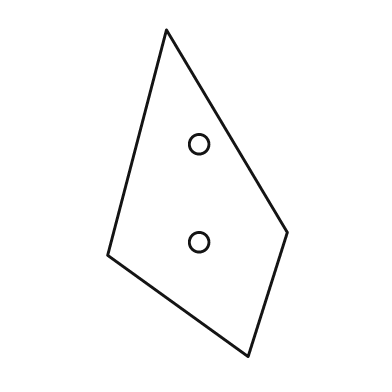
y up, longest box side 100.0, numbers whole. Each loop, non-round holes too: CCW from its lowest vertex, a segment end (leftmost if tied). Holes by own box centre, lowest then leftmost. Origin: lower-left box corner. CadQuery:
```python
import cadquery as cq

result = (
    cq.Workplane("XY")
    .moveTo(43.0, 0.0)
    .lineTo(55.0, 38.0)
    .lineTo(18.0, 100.0)
    .lineTo(0.0, 31.0)
    .close()
    .moveTo(28.0, 35.0)
    .circle(3.0)
    .moveTo(28.0, 65.0)
    .circle(3.0)
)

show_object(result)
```